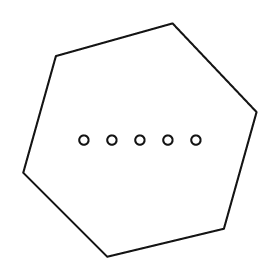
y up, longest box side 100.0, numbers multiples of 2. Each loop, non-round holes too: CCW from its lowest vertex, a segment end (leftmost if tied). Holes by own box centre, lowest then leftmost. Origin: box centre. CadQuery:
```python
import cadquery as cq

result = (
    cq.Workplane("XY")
    .moveTo(-14.0, -50.0)
    .lineTo(36.0, -38.0)
    .lineTo(50.0, 12.0)
    .lineTo(14.0, 50.0)
    .lineTo(-36.0, 36.0)
    .lineTo(-50.0, -14.0)
    .close()
    .moveTo(-24.0, 0.0)
    .circle(2.0)
    .moveTo(-12.0, 0.0)
    .circle(2.0)
    .moveTo(0.0, 0.0)
    .circle(2.0)
    .moveTo(12.0, 0.0)
    .circle(2.0)
    .moveTo(24.0, 0.0)
    .circle(2.0)
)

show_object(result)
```